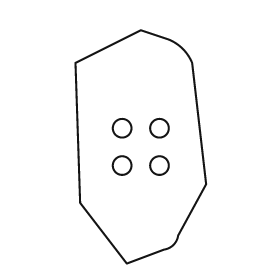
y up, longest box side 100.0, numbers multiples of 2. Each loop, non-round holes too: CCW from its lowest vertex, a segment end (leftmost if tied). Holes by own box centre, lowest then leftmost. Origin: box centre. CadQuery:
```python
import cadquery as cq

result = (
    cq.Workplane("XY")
    .moveTo(-6.0, -50.0)
    .lineTo(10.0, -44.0)
    .threePointArc((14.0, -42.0), (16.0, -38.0))
    .lineTo(28.0, -16.0)
    .lineTo(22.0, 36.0)
    .threePointArc((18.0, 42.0), (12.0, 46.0))
    .lineTo(0.0, 50.0)
    .lineTo(-28.0, 36.0)
    .lineTo(-26.0, -24.0)
    .close()
    .moveTo(-8.0, -8.0)
    .circle(4.0)
    .moveTo(8.0, -8.0)
    .circle(4.0)
    .moveTo(-8.0, 8.0)
    .circle(4.0)
    .moveTo(8.0, 8.0)
    .circle(4.0)
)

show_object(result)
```